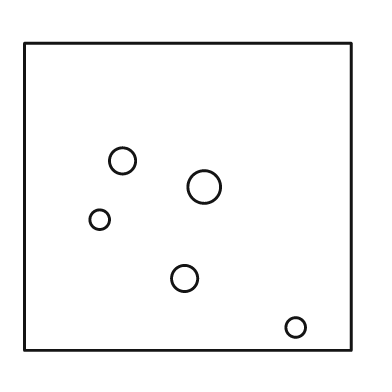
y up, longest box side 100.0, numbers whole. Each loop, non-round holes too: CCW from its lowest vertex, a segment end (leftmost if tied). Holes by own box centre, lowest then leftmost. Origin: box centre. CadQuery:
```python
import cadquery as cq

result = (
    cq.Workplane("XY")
    .moveTo(-50.0, -47.0)
    .lineTo(50.0, -47.0)
    .lineTo(50.0, 47.0)
    .lineTo(-50.0, 47.0)
    .close()
    .moveTo(33.0, -40.0)
    .circle(3.0)
    .moveTo(-1.0, -25.0)
    .circle(4.0)
    .moveTo(-27.0, -7.0)
    .circle(3.0)
    .moveTo(5.0, 3.0)
    .circle(5.0)
    .moveTo(-20.0, 11.0)
    .circle(4.0)
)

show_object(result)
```